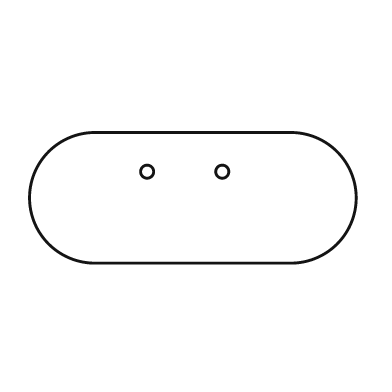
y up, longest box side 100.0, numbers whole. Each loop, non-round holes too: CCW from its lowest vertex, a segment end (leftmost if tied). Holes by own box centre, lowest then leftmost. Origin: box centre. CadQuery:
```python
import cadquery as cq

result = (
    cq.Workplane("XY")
    .moveTo(-30.0, -20.0)
    .lineTo(30.0, -20.0)
    .threePointArc((50.0, 0.0), (30.0, 20.0))
    .lineTo(-30.0, 20.0)
    .threePointArc((-50.0, 0.0), (-30.0, -20.0))
    .close()
    .moveTo(-14.0, 8.0)
    .circle(2.0)
    .moveTo(9.0, 8.0)
    .circle(2.0)
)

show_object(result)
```